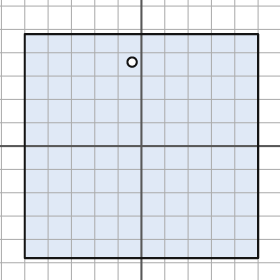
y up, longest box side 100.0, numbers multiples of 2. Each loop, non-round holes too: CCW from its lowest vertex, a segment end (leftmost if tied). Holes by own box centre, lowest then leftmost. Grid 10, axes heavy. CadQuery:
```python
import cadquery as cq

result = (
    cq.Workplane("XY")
    .moveTo(-50.0, -48.0)
    .lineTo(50.0, -48.0)
    .lineTo(50.0, 48.0)
    .lineTo(-50.0, 48.0)
    .close()
    .moveTo(-4.0, 36.0)
    .circle(2.0)
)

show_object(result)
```